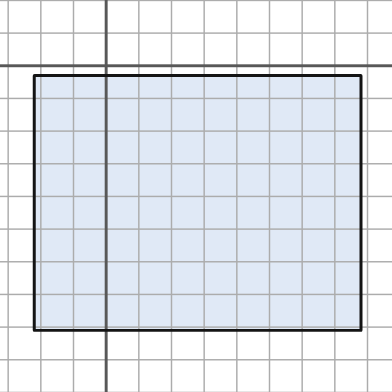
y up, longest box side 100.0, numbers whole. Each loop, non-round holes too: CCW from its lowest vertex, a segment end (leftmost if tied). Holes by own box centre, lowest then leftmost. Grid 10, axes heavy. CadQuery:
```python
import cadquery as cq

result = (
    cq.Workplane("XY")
    .moveTo(-22.0, -81.0)
    .lineTo(78.0, -81.0)
    .lineTo(78.0, -3.0)
    .lineTo(-22.0, -3.0)
    .close()
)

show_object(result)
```